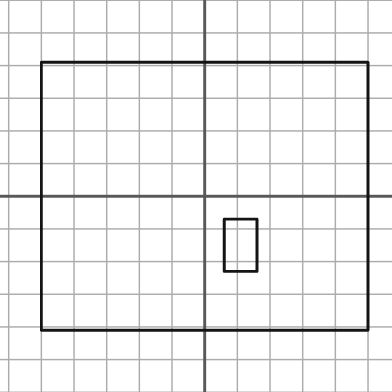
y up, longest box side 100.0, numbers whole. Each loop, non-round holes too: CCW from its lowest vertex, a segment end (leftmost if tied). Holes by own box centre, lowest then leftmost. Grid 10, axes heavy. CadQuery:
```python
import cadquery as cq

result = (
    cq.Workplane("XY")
    .moveTo(-50.0, -41.0)
    .lineTo(50.0, -41.0)
    .lineTo(50.0, 41.0)
    .lineTo(-50.0, 41.0)
    .close()
    .moveTo(6.0, -23.0)
    .lineTo(16.0, -23.0)
    .lineTo(16.0, -7.0)
    .lineTo(6.0, -7.0)
    .close()
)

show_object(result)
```